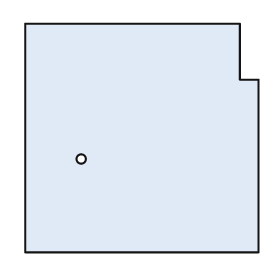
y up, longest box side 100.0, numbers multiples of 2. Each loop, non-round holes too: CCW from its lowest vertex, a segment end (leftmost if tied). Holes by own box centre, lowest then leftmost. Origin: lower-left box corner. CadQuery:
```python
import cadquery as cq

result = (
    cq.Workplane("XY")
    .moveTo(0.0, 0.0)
    .lineTo(100.0, 0.0)
    .lineTo(100.0, 74.0)
    .lineTo(92.0, 74.0)
    .lineTo(92.0, 98.0)
    .lineTo(0.0, 98.0)
    .close()
    .moveTo(24.0, 40.0)
    .circle(2.0)
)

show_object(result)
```